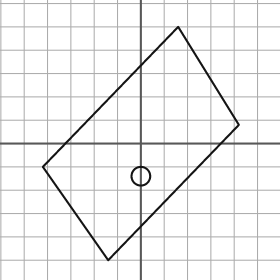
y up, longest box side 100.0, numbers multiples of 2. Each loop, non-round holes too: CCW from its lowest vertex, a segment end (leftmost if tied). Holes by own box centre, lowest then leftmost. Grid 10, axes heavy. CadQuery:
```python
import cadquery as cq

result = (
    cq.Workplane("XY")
    .moveTo(-14.0, -50.0)
    .lineTo(42.0, 8.0)
    .lineTo(16.0, 50.0)
    .lineTo(-42.0, -10.0)
    .close()
    .moveTo(0.0, -14.0)
    .circle(4.0)
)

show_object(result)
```